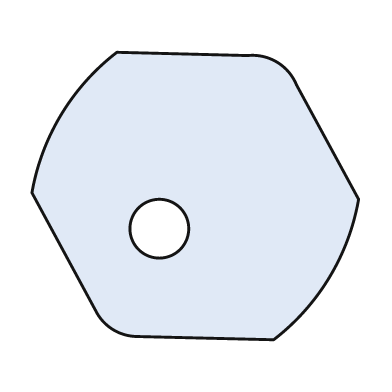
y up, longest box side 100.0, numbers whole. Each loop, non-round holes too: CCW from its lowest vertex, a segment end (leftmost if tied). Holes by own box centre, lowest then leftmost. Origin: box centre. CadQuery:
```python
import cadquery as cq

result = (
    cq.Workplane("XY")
    .moveTo(24.0, -44.0)
    .threePointArc((41.0, -25.0), (50.0, -1.0))
    .lineTo(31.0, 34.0)
    .threePointArc((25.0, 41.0), (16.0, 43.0))
    .lineTo(-24.0, 44.0)
    .threePointArc((-41.0, 25.0), (-50.0, 1.0))
    .lineTo(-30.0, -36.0)
    .threePointArc((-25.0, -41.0), (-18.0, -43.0))
    .close()
    .moveTo(-11.0, -10.0)
    .circle(9.0)
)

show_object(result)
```